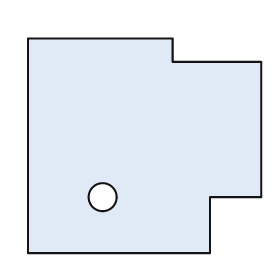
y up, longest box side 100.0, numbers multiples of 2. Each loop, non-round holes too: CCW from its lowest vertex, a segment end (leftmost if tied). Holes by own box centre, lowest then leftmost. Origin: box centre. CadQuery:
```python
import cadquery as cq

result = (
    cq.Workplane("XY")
    .moveTo(-50.0, -46.0)
    .lineTo(28.0, -46.0)
    .lineTo(28.0, -22.0)
    .lineTo(50.0, -22.0)
    .lineTo(50.0, 36.0)
    .lineTo(12.0, 36.0)
    .lineTo(12.0, 46.0)
    .lineTo(-50.0, 46.0)
    .close()
    .moveTo(-18.0, -22.0)
    .circle(6.0)
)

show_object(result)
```